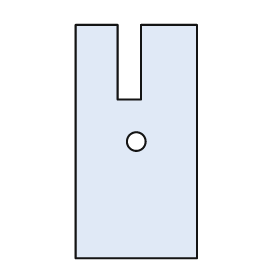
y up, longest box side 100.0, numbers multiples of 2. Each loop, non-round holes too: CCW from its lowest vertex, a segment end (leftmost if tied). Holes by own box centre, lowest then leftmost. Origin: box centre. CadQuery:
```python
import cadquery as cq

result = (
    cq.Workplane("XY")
    .moveTo(-26.0, -50.0)
    .lineTo(26.0, -50.0)
    .lineTo(26.0, 50.0)
    .lineTo(2.0, 50.0)
    .lineTo(2.0, 18.0)
    .lineTo(-8.0, 18.0)
    .lineTo(-8.0, 50.0)
    .lineTo(-26.0, 50.0)
    .close()
    .moveTo(0.0, 0.0)
    .circle(4.0)
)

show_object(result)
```